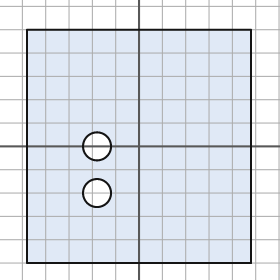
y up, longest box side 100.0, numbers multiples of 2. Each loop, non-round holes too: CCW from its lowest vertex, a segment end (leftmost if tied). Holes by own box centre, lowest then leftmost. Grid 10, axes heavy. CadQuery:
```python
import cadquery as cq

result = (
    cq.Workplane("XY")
    .moveTo(-48.0, -50.0)
    .lineTo(48.0, -50.0)
    .lineTo(48.0, 50.0)
    .lineTo(-48.0, 50.0)
    .close()
    .moveTo(-18.0, -20.0)
    .circle(6.0)
    .moveTo(-18.0, 0.0)
    .circle(6.0)
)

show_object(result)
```